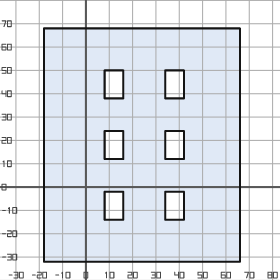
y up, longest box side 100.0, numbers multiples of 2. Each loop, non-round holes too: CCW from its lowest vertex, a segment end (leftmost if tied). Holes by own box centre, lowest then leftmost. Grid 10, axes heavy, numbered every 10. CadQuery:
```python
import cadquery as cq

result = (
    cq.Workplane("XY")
    .moveTo(-18.0, -32.0)
    .lineTo(66.0, -32.0)
    .lineTo(66.0, 68.0)
    .lineTo(-18.0, 68.0)
    .close()
    .moveTo(8.0, -14.0)
    .lineTo(16.0, -14.0)
    .lineTo(16.0, -2.0)
    .lineTo(8.0, -2.0)
    .close()
    .moveTo(34.0, -14.0)
    .lineTo(42.0, -14.0)
    .lineTo(42.0, -2.0)
    .lineTo(34.0, -2.0)
    .close()
    .moveTo(8.0, 12.0)
    .lineTo(16.0, 12.0)
    .lineTo(16.0, 24.0)
    .lineTo(8.0, 24.0)
    .close()
    .moveTo(34.0, 12.0)
    .lineTo(42.0, 12.0)
    .lineTo(42.0, 24.0)
    .lineTo(34.0, 24.0)
    .close()
    .moveTo(8.0, 38.0)
    .lineTo(16.0, 38.0)
    .lineTo(16.0, 50.0)
    .lineTo(8.0, 50.0)
    .close()
    .moveTo(34.0, 38.0)
    .lineTo(42.0, 38.0)
    .lineTo(42.0, 50.0)
    .lineTo(34.0, 50.0)
    .close()
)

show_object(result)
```